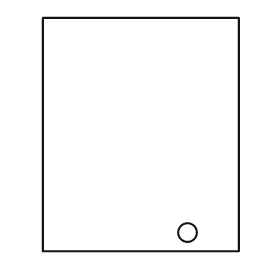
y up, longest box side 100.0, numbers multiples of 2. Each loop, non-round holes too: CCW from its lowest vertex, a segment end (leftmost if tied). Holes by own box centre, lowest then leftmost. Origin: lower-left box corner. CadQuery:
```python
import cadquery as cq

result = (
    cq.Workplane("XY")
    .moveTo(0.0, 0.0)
    .lineTo(84.0, 0.0)
    .lineTo(84.0, 100.0)
    .lineTo(0.0, 100.0)
    .close()
    .moveTo(62.0, 8.0)
    .circle(4.0)
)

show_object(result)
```